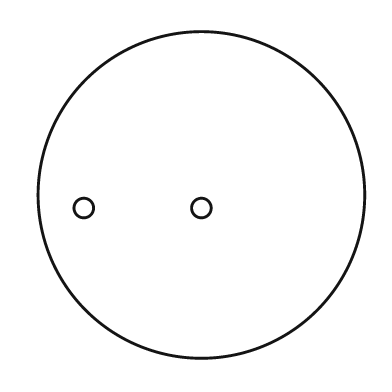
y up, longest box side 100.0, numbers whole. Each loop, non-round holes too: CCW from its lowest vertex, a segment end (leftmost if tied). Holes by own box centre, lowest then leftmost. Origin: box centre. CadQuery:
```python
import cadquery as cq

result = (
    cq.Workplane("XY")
    .moveTo(0.0, 0.0)
    .circle(50.0)
    .moveTo(-36.0, -4.0)
    .circle(3.0)
    .moveTo(0.0, -4.0)
    .circle(3.0)
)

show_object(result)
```